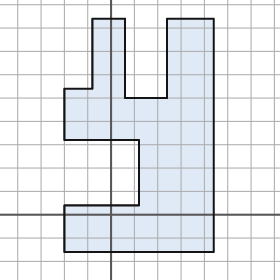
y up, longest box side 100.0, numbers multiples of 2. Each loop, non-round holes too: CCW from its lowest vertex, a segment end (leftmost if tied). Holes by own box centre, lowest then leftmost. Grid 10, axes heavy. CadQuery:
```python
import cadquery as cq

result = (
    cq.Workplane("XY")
    .moveTo(-20.0, -16.0)
    .lineTo(44.0, -16.0)
    .lineTo(44.0, 84.0)
    .lineTo(24.0, 84.0)
    .lineTo(24.0, 50.0)
    .lineTo(6.0, 50.0)
    .lineTo(6.0, 84.0)
    .lineTo(-8.0, 84.0)
    .lineTo(-8.0, 54.0)
    .lineTo(-20.0, 54.0)
    .lineTo(-20.0, 32.0)
    .lineTo(12.0, 32.0)
    .lineTo(12.0, 4.0)
    .lineTo(-20.0, 4.0)
    .close()
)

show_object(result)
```